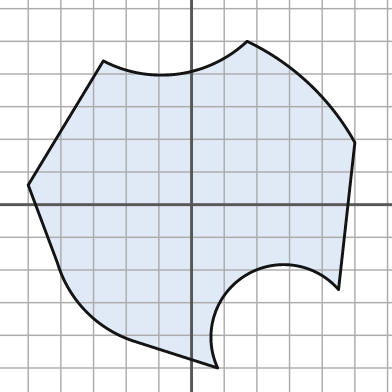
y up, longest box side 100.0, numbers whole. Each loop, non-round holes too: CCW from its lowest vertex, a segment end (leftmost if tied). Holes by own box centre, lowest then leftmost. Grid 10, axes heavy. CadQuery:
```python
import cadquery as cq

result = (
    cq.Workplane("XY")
    .moveTo(8.0, -50.0)
    .threePointArc((16.0, -22.0), (45.0, -26.0))
    .lineTo(50.0, 19.0)
    .threePointArc((36.0, 37.0), (17.0, 50.0))
    .threePointArc((-4.0, 40.0), (-27.0, 44.0))
    .lineTo(-50.0, 6.0)
    .lineTo(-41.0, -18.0)
    .threePointArc((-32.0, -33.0), (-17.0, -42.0))
    .close()
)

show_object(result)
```